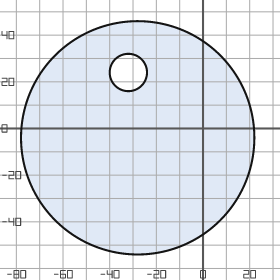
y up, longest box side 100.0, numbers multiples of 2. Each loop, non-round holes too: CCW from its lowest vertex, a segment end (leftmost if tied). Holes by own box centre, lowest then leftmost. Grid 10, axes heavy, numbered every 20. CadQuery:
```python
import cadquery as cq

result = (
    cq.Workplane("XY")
    .moveTo(-28.0, -4.0)
    .circle(50.0)
    .moveTo(-32.0, 24.0)
    .circle(8.0)
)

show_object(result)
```